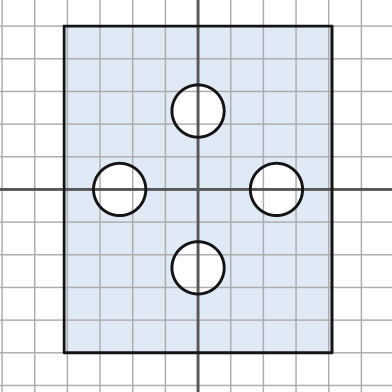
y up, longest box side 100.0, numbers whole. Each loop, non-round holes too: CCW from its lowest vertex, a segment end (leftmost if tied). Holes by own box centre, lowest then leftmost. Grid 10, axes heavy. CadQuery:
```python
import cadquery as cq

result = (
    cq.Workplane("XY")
    .moveTo(-41.0, -50.0)
    .lineTo(41.0, -50.0)
    .lineTo(41.0, 50.0)
    .lineTo(-41.0, 50.0)
    .close()
    .moveTo(0.0, -24.0)
    .circle(8.0)
    .moveTo(-24.0, 0.0)
    .circle(8.0)
    .moveTo(24.0, 0.0)
    .circle(8.0)
    .moveTo(0.0, 24.0)
    .circle(8.0)
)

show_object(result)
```